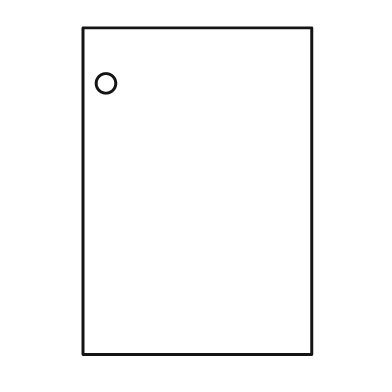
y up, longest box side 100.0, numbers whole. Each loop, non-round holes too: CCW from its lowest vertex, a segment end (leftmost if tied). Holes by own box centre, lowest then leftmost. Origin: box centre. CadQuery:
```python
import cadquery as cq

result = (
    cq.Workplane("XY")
    .moveTo(-35.0, -50.0)
    .lineTo(35.0, -50.0)
    .lineTo(35.0, 50.0)
    .lineTo(-35.0, 50.0)
    .close()
    .moveTo(-28.0, 33.0)
    .circle(3.0)
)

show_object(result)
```